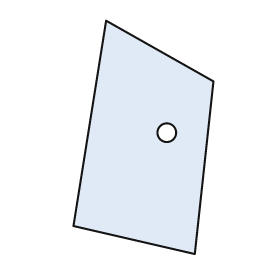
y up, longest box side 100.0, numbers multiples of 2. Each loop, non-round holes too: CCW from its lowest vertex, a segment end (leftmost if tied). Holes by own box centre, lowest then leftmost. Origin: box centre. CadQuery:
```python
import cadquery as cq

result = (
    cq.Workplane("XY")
    .moveTo(22.0, -50.0)
    .lineTo(30.0, 24.0)
    .lineTo(-16.0, 50.0)
    .lineTo(-30.0, -38.0)
    .close()
    .moveTo(10.0, 2.0)
    .circle(4.0)
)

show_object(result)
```